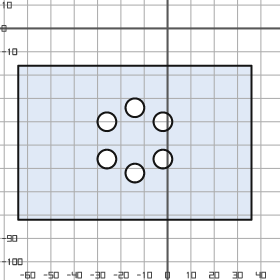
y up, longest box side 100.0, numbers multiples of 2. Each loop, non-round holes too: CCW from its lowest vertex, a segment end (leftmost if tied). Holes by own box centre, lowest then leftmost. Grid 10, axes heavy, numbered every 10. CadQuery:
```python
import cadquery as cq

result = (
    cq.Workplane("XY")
    .moveTo(-64.0, -82.0)
    .lineTo(36.0, -82.0)
    .lineTo(36.0, -16.0)
    .lineTo(-64.0, -16.0)
    .close()
    .moveTo(-14.0, -62.0)
    .circle(4.0)
    .moveTo(-26.0, -56.0)
    .circle(4.0)
    .moveTo(-2.0, -56.0)
    .circle(4.0)
    .moveTo(-26.0, -40.0)
    .circle(4.0)
    .moveTo(-2.0, -40.0)
    .circle(4.0)
    .moveTo(-14.0, -34.0)
    .circle(4.0)
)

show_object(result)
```